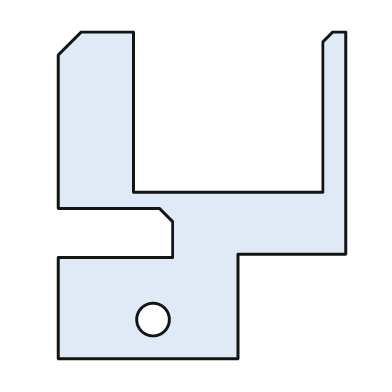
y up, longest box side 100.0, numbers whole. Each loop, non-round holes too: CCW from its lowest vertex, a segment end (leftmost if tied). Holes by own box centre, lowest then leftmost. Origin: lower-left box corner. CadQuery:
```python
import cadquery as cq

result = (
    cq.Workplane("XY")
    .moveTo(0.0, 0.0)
    .lineTo(55.0, 0.0)
    .lineTo(55.0, 32.0)
    .lineTo(88.0, 32.0)
    .lineTo(88.0, 100.0)
    .lineTo(84.0, 100.0)
    .lineTo(81.0, 97.0)
    .lineTo(81.0, 51.0)
    .lineTo(23.0, 51.0)
    .lineTo(23.0, 100.0)
    .lineTo(7.0, 100.0)
    .lineTo(0.0, 93.0)
    .lineTo(0.0, 46.0)
    .lineTo(31.0, 46.0)
    .lineTo(35.0, 42.0)
    .lineTo(35.0, 31.0)
    .lineTo(0.0, 31.0)
    .close()
    .moveTo(29.0, 12.0)
    .circle(5.0)
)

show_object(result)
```